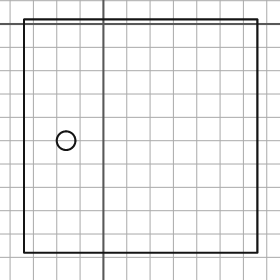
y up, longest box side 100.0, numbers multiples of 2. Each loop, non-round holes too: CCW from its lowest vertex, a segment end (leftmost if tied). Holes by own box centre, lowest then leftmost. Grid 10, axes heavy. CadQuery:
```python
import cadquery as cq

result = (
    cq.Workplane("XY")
    .moveTo(-34.0, -98.0)
    .lineTo(66.0, -98.0)
    .lineTo(66.0, 2.0)
    .lineTo(-34.0, 2.0)
    .close()
    .moveTo(-16.0, -50.0)
    .circle(4.0)
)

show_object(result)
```